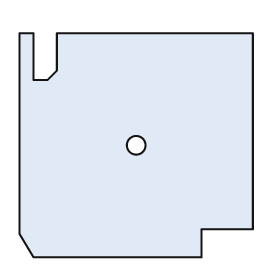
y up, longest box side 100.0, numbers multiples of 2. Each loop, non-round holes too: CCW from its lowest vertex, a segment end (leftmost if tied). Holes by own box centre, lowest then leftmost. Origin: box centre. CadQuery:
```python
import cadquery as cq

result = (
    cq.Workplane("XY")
    .moveTo(-44.0, -48.0)
    .lineTo(28.0, -48.0)
    .lineTo(28.0, -36.0)
    .lineTo(50.0, -36.0)
    .lineTo(50.0, 48.0)
    .lineTo(-34.0, 48.0)
    .lineTo(-34.0, 32.0)
    .lineTo(-38.0, 28.0)
    .lineTo(-44.0, 28.0)
    .lineTo(-44.0, 48.0)
    .lineTo(-50.0, 48.0)
    .lineTo(-50.0, -38.0)
    .close()
    .moveTo(0.0, 0.0)
    .circle(4.0)
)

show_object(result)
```